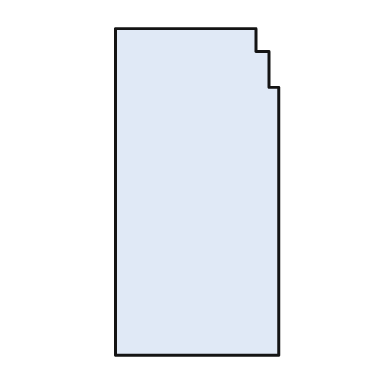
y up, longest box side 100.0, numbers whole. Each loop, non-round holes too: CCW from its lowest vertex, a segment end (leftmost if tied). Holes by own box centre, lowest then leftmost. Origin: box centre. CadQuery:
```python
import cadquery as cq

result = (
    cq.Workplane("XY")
    .moveTo(-25.0, -50.0)
    .lineTo(25.0, -50.0)
    .lineTo(25.0, 32.0)
    .lineTo(22.0, 32.0)
    .lineTo(22.0, 43.0)
    .lineTo(18.0, 43.0)
    .lineTo(18.0, 50.0)
    .lineTo(-25.0, 50.0)
    .close()
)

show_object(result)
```